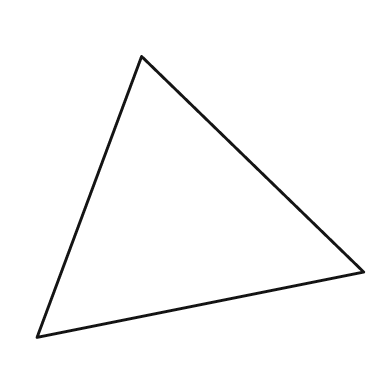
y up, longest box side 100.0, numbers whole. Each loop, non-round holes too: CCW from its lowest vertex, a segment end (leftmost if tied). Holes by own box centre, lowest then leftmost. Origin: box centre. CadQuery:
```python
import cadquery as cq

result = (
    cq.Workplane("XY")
    .moveTo(-50.0, -43.0)
    .lineTo(50.0, -23.0)
    .lineTo(-18.0, 43.0)
    .close()
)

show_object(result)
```